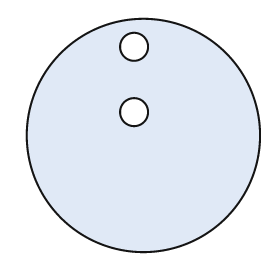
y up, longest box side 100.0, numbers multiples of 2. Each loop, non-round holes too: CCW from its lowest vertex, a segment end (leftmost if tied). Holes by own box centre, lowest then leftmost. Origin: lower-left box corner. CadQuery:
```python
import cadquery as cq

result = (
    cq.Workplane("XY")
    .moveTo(50.0, 50.0)
    .circle(50.0)
    .moveTo(46.0, 60.0)
    .circle(6.0)
    .moveTo(46.0, 88.0)
    .circle(6.0)
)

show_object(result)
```